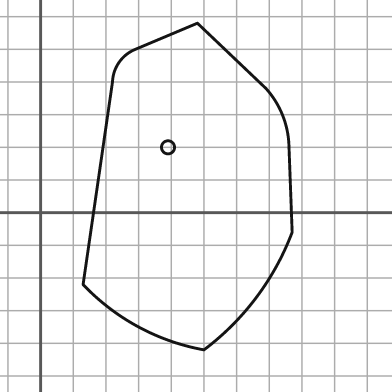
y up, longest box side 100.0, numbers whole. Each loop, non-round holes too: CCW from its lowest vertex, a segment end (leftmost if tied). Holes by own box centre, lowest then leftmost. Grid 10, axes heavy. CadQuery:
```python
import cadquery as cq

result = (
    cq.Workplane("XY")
    .moveTo(50.0, -42.0)
    .threePointArc((66.0, -26.0), (77.0, -6.0))
    .lineTo(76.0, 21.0)
    .threePointArc((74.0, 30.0), (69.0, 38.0))
    .lineTo(48.0, 58.0)
    .lineTo(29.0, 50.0)
    .threePointArc((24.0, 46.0), (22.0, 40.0))
    .lineTo(13.0, -22.0)
    .threePointArc((30.0, -35.0), (50.0, -42.0))
    .close()
    .moveTo(39.0, 20.0)
    .circle(2.0)
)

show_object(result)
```